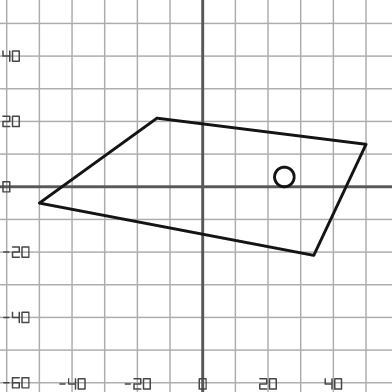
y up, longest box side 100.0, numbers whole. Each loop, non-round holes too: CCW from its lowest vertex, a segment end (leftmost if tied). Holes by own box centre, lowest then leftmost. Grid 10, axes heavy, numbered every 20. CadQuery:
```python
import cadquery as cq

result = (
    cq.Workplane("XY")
    .moveTo(34.0, -21.0)
    .lineTo(50.0, 13.0)
    .lineTo(-14.0, 21.0)
    .lineTo(-50.0, -5.0)
    .close()
    .moveTo(25.0, 3.0)
    .circle(3.0)
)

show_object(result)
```